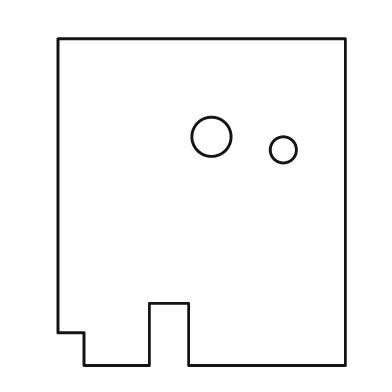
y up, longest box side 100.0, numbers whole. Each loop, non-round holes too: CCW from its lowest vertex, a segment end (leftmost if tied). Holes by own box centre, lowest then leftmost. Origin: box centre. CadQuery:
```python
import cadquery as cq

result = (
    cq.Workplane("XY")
    .moveTo(-36.0, -50.0)
    .lineTo(-16.0, -50.0)
    .lineTo(-16.0, -31.0)
    .lineTo(-4.0, -31.0)
    .lineTo(-4.0, -50.0)
    .lineTo(44.0, -50.0)
    .lineTo(44.0, 50.0)
    .lineTo(-44.0, 50.0)
    .lineTo(-44.0, -40.0)
    .lineTo(-36.0, -40.0)
    .close()
    .moveTo(25.0, 16.0)
    .circle(4.0)
    .moveTo(3.0, 20.0)
    .circle(6.0)
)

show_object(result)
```